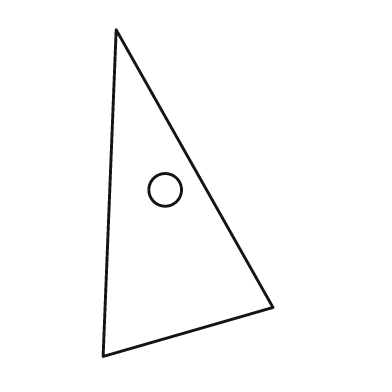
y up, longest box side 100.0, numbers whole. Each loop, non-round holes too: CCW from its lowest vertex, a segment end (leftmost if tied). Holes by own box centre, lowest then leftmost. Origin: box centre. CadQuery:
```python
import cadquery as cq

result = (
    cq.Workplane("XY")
    .moveTo(-26.0, -50.0)
    .lineTo(26.0, -35.0)
    .lineTo(-22.0, 50.0)
    .close()
    .moveTo(-7.0, 1.0)
    .circle(5.0)
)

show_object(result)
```